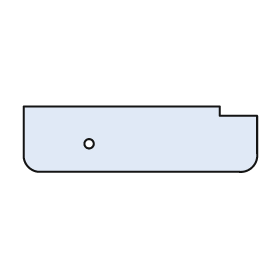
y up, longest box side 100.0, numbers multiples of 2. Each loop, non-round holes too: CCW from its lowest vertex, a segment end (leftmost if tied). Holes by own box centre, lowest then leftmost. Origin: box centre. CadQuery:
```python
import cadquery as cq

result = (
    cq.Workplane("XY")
    .moveTo(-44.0, -14.0)
    .lineTo(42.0, -14.0)
    .threePointArc((48.0, -12.0), (50.0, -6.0))
    .lineTo(50.0, 10.0)
    .lineTo(34.0, 10.0)
    .lineTo(34.0, 14.0)
    .lineTo(-50.0, 14.0)
    .lineTo(-50.0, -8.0)
    .threePointArc((-48.0, -12.0), (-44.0, -14.0))
    .close()
    .moveTo(-22.0, -2.0)
    .circle(2.0)
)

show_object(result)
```